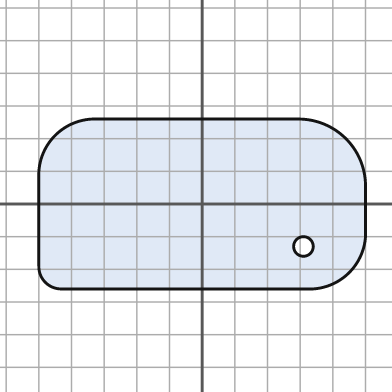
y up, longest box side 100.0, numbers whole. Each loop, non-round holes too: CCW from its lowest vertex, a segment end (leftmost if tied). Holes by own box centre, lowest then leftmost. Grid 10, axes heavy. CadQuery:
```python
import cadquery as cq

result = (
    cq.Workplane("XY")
    .moveTo(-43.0, -26.0)
    .lineTo(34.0, -26.0)
    .threePointArc((45.0, -21.0), (50.0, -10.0))
    .lineTo(50.0, 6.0)
    .threePointArc((44.0, 20.0), (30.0, 26.0))
    .lineTo(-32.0, 26.0)
    .threePointArc((-45.0, 21.0), (-50.0, 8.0))
    .lineTo(-50.0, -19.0)
    .threePointArc((-48.0, -24.0), (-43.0, -26.0))
    .close()
    .moveTo(31.0, -13.0)
    .circle(3.0)
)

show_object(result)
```